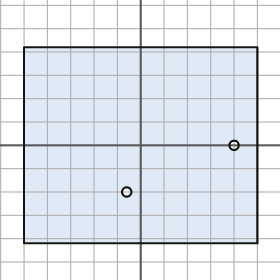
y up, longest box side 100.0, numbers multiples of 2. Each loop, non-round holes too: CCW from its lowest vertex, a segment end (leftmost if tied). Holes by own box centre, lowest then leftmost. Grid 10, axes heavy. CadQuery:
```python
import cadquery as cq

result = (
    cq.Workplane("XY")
    .moveTo(-50.0, -42.0)
    .lineTo(50.0, -42.0)
    .lineTo(50.0, 42.0)
    .lineTo(-50.0, 42.0)
    .close()
    .moveTo(-6.0, -20.0)
    .circle(2.0)
    .moveTo(40.0, 0.0)
    .circle(2.0)
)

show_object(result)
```